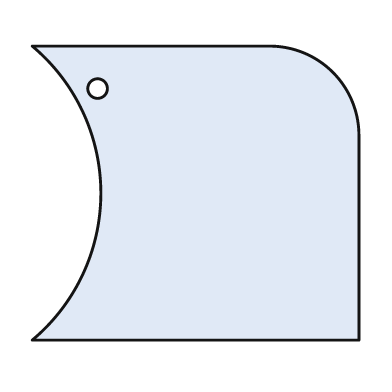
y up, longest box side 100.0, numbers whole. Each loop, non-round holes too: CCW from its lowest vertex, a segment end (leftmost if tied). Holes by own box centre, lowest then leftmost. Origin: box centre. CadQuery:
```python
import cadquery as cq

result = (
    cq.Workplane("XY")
    .moveTo(-50.0, -45.0)
    .lineTo(50.0, -45.0)
    .lineTo(50.0, 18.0)
    .threePointArc((42.0, 37.0), (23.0, 45.0))
    .lineTo(-50.0, 45.0)
    .threePointArc((-29.0, 0.0), (-50.0, -45.0))
    .close()
    .moveTo(-30.0, 32.0)
    .circle(3.0)
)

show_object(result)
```